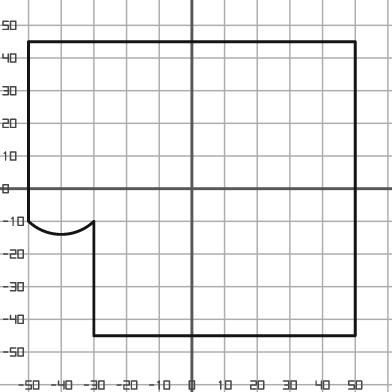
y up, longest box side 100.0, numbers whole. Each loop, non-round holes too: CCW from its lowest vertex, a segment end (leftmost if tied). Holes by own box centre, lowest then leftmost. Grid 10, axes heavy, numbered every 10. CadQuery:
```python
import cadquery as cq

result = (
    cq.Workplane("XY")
    .moveTo(-30.0, -45.0)
    .lineTo(50.0, -45.0)
    .lineTo(50.0, 45.0)
    .lineTo(-50.0, 45.0)
    .lineTo(-50.0, -10.0)
    .threePointArc((-40.0, -14.0), (-30.0, -10.0))
    .close()
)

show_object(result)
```